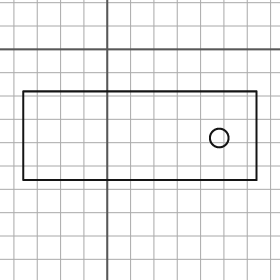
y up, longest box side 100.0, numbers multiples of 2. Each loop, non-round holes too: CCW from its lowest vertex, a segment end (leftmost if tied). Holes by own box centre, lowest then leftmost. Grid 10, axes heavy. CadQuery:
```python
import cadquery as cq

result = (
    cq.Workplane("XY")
    .moveTo(-36.0, -56.0)
    .lineTo(64.0, -56.0)
    .lineTo(64.0, -18.0)
    .lineTo(-36.0, -18.0)
    .close()
    .moveTo(48.0, -38.0)
    .circle(4.0)
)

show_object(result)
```